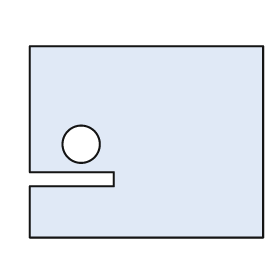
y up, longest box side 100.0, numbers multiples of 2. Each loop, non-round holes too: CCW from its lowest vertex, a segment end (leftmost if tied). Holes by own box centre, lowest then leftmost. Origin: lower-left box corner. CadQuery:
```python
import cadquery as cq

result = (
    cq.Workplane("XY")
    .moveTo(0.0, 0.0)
    .lineTo(100.0, 0.0)
    .lineTo(100.0, 82.0)
    .lineTo(0.0, 82.0)
    .lineTo(0.0, 28.0)
    .lineTo(36.0, 28.0)
    .lineTo(36.0, 22.0)
    .lineTo(0.0, 22.0)
    .close()
    .moveTo(22.0, 40.0)
    .circle(8.0)
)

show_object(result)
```